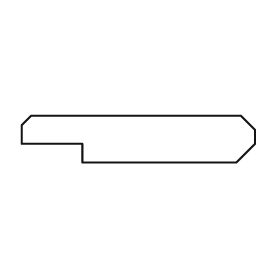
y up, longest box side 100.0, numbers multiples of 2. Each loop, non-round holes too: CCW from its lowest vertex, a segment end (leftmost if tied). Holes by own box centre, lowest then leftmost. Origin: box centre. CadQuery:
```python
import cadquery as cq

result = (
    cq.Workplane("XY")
    .moveTo(-24.0, -10.0)
    .lineTo(42.0, -10.0)
    .lineTo(50.0, -2.0)
    .lineTo(50.0, 4.0)
    .lineTo(44.0, 10.0)
    .lineTo(-46.0, 10.0)
    .lineTo(-50.0, 6.0)
    .lineTo(-50.0, -2.0)
    .lineTo(-24.0, -2.0)
    .close()
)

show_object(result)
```